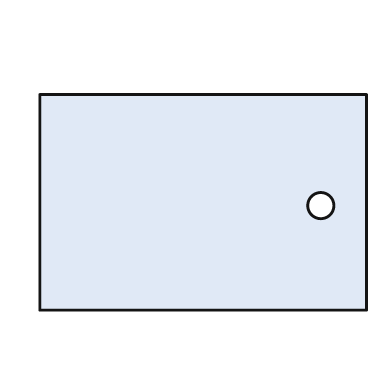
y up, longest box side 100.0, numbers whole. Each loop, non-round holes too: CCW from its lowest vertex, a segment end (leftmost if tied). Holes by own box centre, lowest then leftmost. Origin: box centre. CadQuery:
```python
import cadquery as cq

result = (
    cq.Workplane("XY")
    .moveTo(-50.0, -33.0)
    .lineTo(50.0, -33.0)
    .lineTo(50.0, 33.0)
    .lineTo(-50.0, 33.0)
    .close()
    .moveTo(36.0, -1.0)
    .circle(4.0)
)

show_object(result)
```